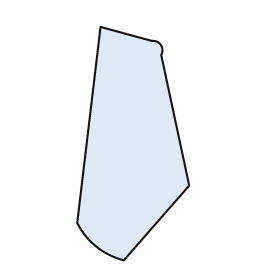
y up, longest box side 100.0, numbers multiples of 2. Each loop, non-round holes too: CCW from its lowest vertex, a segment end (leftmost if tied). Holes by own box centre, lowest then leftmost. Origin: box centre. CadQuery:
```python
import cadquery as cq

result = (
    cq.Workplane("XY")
    .moveTo(-4.0, -50.0)
    .lineTo(24.0, -18.0)
    .lineTo(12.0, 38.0)
    .threePointArc((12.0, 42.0), (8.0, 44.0))
    .lineTo(-14.0, 50.0)
    .lineTo(-24.0, -34.0)
    .threePointArc((-16.0, -44.0), (-4.0, -50.0))
    .close()
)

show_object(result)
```